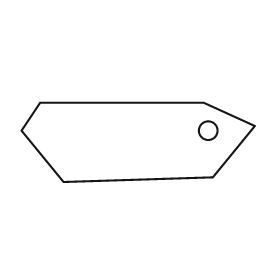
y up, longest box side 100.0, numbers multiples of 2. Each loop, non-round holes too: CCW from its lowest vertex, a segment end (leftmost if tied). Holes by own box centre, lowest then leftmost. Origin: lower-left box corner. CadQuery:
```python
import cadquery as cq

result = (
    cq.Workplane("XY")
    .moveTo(18.0, 0.0)
    .lineTo(82.0, 2.0)
    .lineTo(100.0, 24.0)
    .lineTo(78.0, 34.0)
    .lineTo(8.0, 34.0)
    .lineTo(0.0, 22.0)
    .close()
    .moveTo(80.0, 22.0)
    .circle(4.0)
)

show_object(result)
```